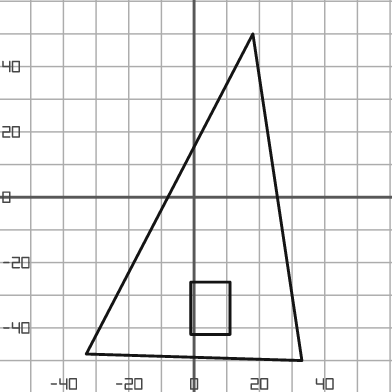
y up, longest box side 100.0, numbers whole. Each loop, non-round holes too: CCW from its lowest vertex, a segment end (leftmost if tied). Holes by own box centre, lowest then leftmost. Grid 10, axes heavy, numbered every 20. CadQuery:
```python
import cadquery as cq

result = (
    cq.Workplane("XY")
    .moveTo(33.0, -50.0)
    .lineTo(18.0, 50.0)
    .lineTo(-33.0, -48.0)
    .close()
    .moveTo(-1.0, -42.0)
    .lineTo(11.0, -42.0)
    .lineTo(11.0, -26.0)
    .lineTo(-1.0, -26.0)
    .close()
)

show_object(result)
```